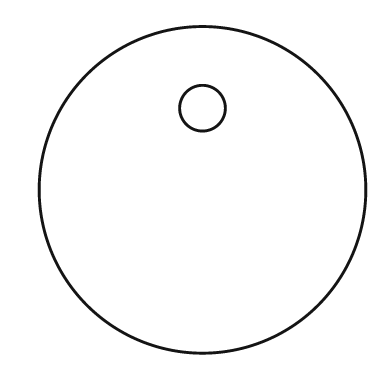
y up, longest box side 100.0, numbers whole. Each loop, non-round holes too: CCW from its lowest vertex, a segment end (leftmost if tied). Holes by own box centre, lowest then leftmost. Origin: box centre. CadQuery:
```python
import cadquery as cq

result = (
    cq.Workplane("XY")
    .moveTo(0.0, 0.0)
    .circle(50.0)
    .moveTo(0.0, 25.0)
    .circle(7.0)
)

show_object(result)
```